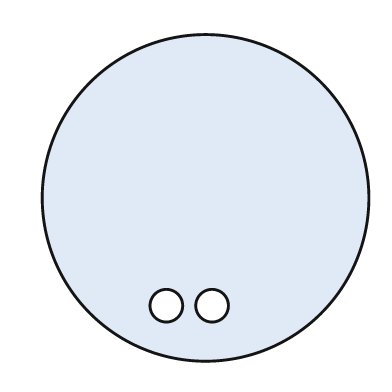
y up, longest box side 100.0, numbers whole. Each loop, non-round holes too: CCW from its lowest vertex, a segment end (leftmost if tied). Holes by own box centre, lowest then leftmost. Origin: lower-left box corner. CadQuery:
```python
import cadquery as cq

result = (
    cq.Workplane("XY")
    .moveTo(50.0, 50.0)
    .circle(50.0)
    .moveTo(38.0, 17.0)
    .circle(5.0)
    .moveTo(52.0, 17.0)
    .circle(5.0)
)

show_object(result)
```